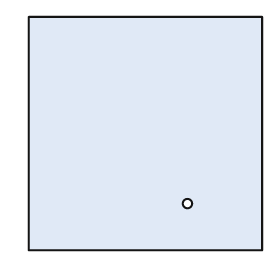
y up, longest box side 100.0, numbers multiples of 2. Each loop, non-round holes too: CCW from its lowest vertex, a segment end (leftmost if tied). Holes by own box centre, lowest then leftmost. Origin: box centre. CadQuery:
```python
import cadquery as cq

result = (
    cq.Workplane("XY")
    .moveTo(-50.0, -50.0)
    .lineTo(50.0, -50.0)
    .lineTo(50.0, 50.0)
    .lineTo(-50.0, 50.0)
    .close()
    .moveTo(18.0, -30.0)
    .circle(2.0)
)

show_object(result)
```